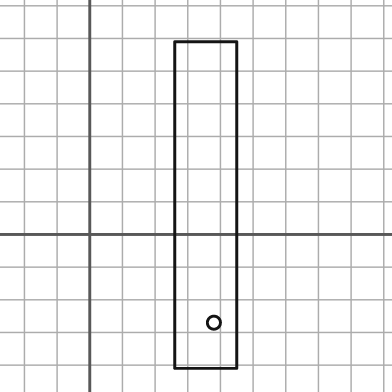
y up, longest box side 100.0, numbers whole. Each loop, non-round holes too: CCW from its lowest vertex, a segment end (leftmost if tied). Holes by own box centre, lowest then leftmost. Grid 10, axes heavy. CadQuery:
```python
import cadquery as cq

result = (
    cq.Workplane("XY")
    .moveTo(26.0, -41.0)
    .lineTo(45.0, -41.0)
    .lineTo(45.0, 59.0)
    .lineTo(26.0, 59.0)
    .close()
    .moveTo(38.0, -27.0)
    .circle(2.0)
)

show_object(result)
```